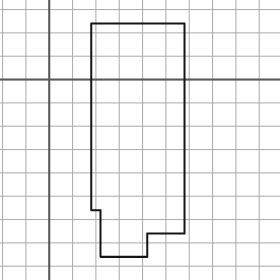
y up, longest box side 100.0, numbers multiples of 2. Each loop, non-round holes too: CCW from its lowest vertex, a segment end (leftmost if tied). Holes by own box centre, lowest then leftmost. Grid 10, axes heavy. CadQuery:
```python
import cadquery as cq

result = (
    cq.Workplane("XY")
    .moveTo(22.0, -76.0)
    .lineTo(42.0, -76.0)
    .lineTo(42.0, -66.0)
    .lineTo(58.0, -66.0)
    .lineTo(58.0, 24.0)
    .lineTo(18.0, 24.0)
    .lineTo(18.0, -56.0)
    .lineTo(22.0, -56.0)
    .close()
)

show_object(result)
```